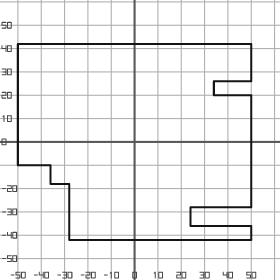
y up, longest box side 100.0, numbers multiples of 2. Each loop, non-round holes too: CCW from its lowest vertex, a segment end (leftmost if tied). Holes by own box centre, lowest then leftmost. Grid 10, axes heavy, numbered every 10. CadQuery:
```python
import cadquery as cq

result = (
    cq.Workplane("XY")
    .moveTo(-28.0, -42.0)
    .lineTo(50.0, -42.0)
    .lineTo(50.0, -36.0)
    .lineTo(24.0, -36.0)
    .lineTo(24.0, -28.0)
    .lineTo(50.0, -28.0)
    .lineTo(50.0, 20.0)
    .lineTo(34.0, 20.0)
    .lineTo(34.0, 26.0)
    .lineTo(50.0, 26.0)
    .lineTo(50.0, 42.0)
    .lineTo(-50.0, 42.0)
    .lineTo(-50.0, -10.0)
    .lineTo(-36.0, -10.0)
    .lineTo(-36.0, -18.0)
    .lineTo(-28.0, -18.0)
    .close()
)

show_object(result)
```